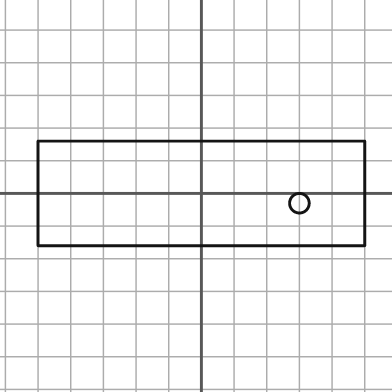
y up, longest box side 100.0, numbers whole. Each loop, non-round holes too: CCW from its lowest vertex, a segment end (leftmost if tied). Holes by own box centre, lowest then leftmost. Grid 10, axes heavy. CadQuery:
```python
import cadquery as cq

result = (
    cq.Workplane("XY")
    .moveTo(-50.0, -16.0)
    .lineTo(50.0, -16.0)
    .lineTo(50.0, 16.0)
    .lineTo(-50.0, 16.0)
    .close()
    .moveTo(30.0, -3.0)
    .circle(3.0)
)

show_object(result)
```